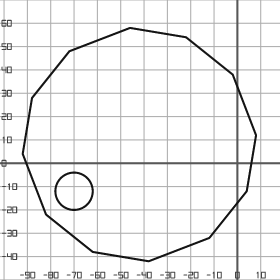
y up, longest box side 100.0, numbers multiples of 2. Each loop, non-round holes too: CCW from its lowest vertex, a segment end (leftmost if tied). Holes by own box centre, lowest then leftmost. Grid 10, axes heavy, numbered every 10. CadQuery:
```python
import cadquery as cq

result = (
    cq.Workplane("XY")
    .moveTo(-38.0, -42.0)
    .lineTo(-12.0, -32.0)
    .lineTo(4.0, -12.0)
    .lineTo(8.0, 12.0)
    .lineTo(-2.0, 38.0)
    .lineTo(-22.0, 54.0)
    .lineTo(-46.0, 58.0)
    .lineTo(-72.0, 48.0)
    .lineTo(-88.0, 28.0)
    .lineTo(-92.0, 4.0)
    .lineTo(-82.0, -22.0)
    .lineTo(-62.0, -38.0)
    .close()
    .moveTo(-70.0, -12.0)
    .circle(8.0)
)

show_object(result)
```